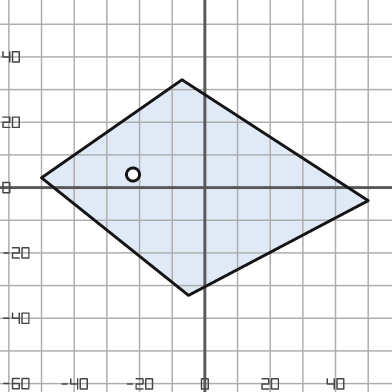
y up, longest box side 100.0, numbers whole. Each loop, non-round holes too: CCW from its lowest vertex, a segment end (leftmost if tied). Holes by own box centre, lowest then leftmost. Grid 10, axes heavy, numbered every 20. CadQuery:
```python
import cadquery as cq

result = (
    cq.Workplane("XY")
    .moveTo(-5.0, -33.0)
    .lineTo(50.0, -4.0)
    .lineTo(-7.0, 33.0)
    .lineTo(-50.0, 3.0)
    .close()
    .moveTo(-22.0, 4.0)
    .circle(2.0)
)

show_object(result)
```